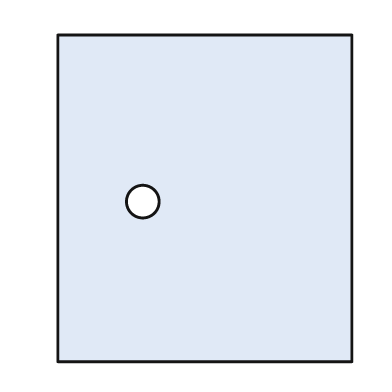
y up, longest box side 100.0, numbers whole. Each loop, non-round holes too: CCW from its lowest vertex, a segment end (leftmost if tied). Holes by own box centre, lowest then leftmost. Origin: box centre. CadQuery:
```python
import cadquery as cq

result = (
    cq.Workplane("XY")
    .moveTo(-45.0, -50.0)
    .lineTo(45.0, -50.0)
    .lineTo(45.0, 50.0)
    .lineTo(-45.0, 50.0)
    .close()
    .moveTo(-19.0, -1.0)
    .circle(5.0)
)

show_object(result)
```